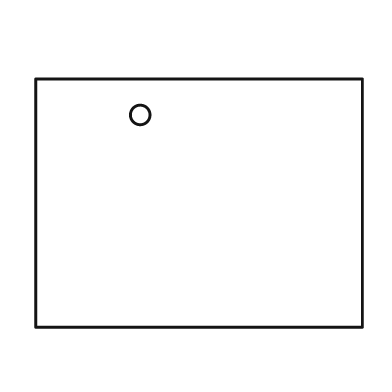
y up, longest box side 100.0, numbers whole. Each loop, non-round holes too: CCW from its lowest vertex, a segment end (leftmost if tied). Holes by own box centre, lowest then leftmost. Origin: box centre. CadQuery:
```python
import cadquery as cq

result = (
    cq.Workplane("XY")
    .moveTo(-50.0, -38.0)
    .lineTo(50.0, -38.0)
    .lineTo(50.0, 38.0)
    .lineTo(-50.0, 38.0)
    .close()
    .moveTo(-18.0, 27.0)
    .circle(3.0)
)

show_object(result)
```